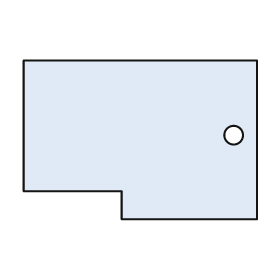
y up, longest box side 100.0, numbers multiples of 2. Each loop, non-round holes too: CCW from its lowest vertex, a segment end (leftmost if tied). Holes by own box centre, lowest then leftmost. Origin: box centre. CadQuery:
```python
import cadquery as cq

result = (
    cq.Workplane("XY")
    .moveTo(-8.0, -34.0)
    .lineTo(50.0, -34.0)
    .lineTo(50.0, 34.0)
    .lineTo(-50.0, 34.0)
    .lineTo(-50.0, -22.0)
    .lineTo(-8.0, -22.0)
    .close()
    .moveTo(40.0, 2.0)
    .circle(4.0)
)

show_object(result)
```